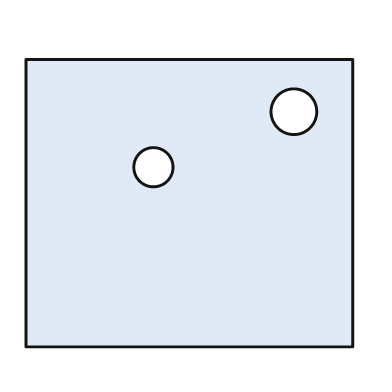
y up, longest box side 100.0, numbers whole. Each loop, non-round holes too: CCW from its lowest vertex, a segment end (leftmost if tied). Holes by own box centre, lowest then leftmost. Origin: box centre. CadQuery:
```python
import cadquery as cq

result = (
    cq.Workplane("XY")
    .moveTo(-50.0, -44.0)
    .lineTo(50.0, -44.0)
    .lineTo(50.0, 44.0)
    .lineTo(-50.0, 44.0)
    .close()
    .moveTo(-11.0, 11.0)
    .circle(6.0)
    .moveTo(32.0, 28.0)
    .circle(7.0)
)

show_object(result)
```